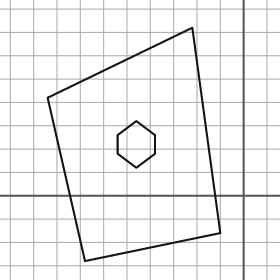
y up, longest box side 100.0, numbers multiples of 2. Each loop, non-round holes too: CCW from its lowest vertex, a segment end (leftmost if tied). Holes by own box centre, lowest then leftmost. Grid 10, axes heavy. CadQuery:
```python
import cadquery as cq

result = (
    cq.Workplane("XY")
    .moveTo(-68.0, -28.0)
    .lineTo(-10.0, -16.0)
    .lineTo(-22.0, 72.0)
    .lineTo(-84.0, 42.0)
    .close()
    .moveTo(-46.0, 12.0)
    .lineTo(-38.0, 18.0)
    .lineTo(-38.0, 26.0)
    .lineTo(-46.0, 32.0)
    .lineTo(-54.0, 26.0)
    .lineTo(-54.0, 18.0)
    .close()
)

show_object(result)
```